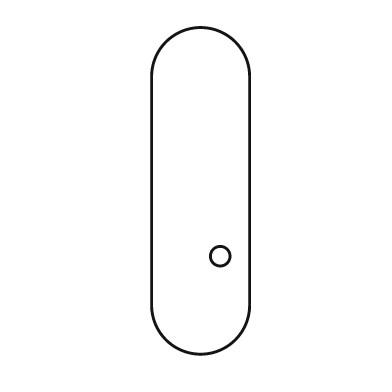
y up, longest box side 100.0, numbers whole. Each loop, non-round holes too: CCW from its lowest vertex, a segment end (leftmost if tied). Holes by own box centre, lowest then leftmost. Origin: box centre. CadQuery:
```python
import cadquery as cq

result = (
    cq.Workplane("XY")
    .moveTo(-15.0, -35.0)
    .threePointArc((0.0, -50.0), (15.0, -35.0))
    .lineTo(15.0, 35.0)
    .threePointArc((0.0, 50.0), (-15.0, 35.0))
    .close()
    .moveTo(6.0, -20.0)
    .circle(3.0)
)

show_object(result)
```